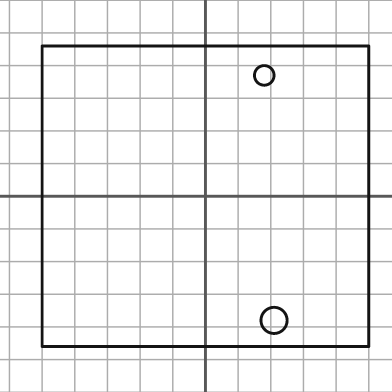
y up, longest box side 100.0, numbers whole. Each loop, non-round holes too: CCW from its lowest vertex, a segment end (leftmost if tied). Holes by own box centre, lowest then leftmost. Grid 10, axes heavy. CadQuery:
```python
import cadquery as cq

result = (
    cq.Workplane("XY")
    .moveTo(-50.0, -46.0)
    .lineTo(50.0, -46.0)
    .lineTo(50.0, 46.0)
    .lineTo(-50.0, 46.0)
    .close()
    .moveTo(21.0, -38.0)
    .circle(4.0)
    .moveTo(18.0, 37.0)
    .circle(3.0)
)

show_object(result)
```